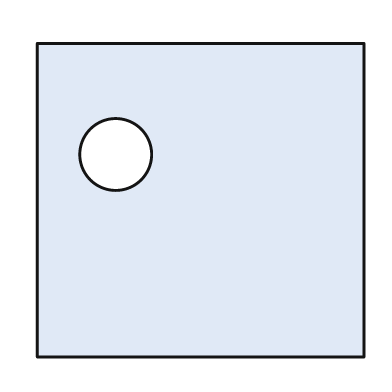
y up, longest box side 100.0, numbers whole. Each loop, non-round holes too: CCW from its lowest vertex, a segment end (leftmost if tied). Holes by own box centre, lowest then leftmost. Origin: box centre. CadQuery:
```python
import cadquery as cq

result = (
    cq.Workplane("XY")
    .moveTo(-50.0, -48.0)
    .lineTo(50.0, -48.0)
    .lineTo(50.0, 48.0)
    .lineTo(-50.0, 48.0)
    .close()
    .moveTo(-26.0, 14.0)
    .circle(11.0)
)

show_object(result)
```